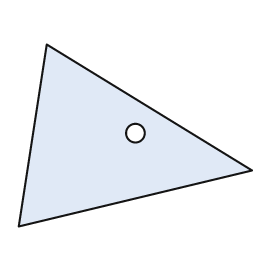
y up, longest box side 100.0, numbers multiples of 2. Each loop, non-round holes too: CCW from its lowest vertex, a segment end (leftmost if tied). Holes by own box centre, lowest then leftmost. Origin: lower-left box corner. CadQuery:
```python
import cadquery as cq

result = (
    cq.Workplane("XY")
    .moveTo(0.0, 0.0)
    .lineTo(100.0, 24.0)
    .lineTo(12.0, 78.0)
    .close()
    .moveTo(50.0, 40.0)
    .circle(4.0)
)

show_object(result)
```